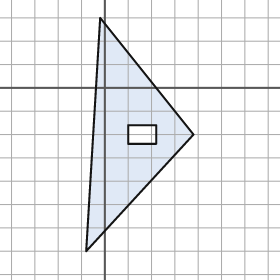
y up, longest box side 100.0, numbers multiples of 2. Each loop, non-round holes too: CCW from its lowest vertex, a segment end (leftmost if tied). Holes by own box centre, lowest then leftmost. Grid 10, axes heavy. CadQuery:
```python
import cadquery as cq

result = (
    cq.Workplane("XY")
    .moveTo(-8.0, -70.0)
    .lineTo(38.0, -20.0)
    .lineTo(-2.0, 30.0)
    .close()
    .moveTo(10.0, -24.0)
    .lineTo(22.0, -24.0)
    .lineTo(22.0, -16.0)
    .lineTo(10.0, -16.0)
    .close()
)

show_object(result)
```